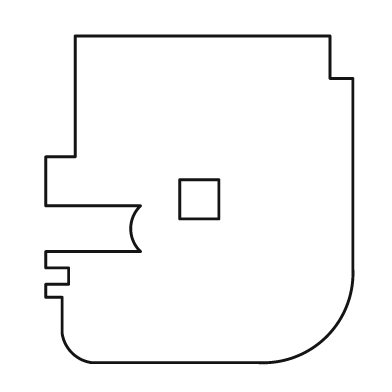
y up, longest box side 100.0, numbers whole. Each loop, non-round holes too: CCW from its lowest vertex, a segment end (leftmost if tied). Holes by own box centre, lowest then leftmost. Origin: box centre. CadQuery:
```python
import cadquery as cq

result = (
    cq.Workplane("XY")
    .moveTo(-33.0, -50.0)
    .lineTo(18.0, -50.0)
    .threePointArc((39.0, -42.0), (47.0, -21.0))
    .lineTo(47.0, 37.0)
    .lineTo(40.0, 37.0)
    .lineTo(40.0, 50.0)
    .lineTo(-38.0, 50.0)
    .lineTo(-38.0, 13.0)
    .lineTo(-47.0, 13.0)
    .lineTo(-47.0, -2.0)
    .lineTo(-18.0, -2.0)
    .threePointArc((-21.0, -9.0), (-18.0, -16.0))
    .lineTo(-47.0, -16.0)
    .lineTo(-47.0, -21.0)
    .lineTo(-40.0, -21.0)
    .lineTo(-40.0, -26.0)
    .lineTo(-47.0, -26.0)
    .lineTo(-47.0, -30.0)
    .lineTo(-42.0, -30.0)
    .lineTo(-42.0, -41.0)
    .threePointArc((-39.0, -47.0), (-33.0, -50.0))
    .close()
    .moveTo(-6.0, -6.0)
    .lineTo(6.0, -6.0)
    .lineTo(6.0, 6.0)
    .lineTo(-6.0, 6.0)
    .close()
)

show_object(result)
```